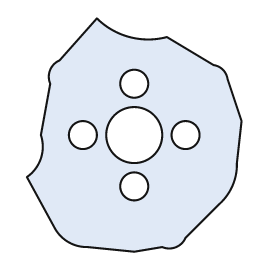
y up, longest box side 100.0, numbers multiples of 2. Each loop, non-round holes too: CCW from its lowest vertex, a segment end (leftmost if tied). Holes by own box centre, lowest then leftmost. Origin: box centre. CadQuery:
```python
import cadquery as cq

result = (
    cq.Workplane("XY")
    .moveTo(0.0, -50.0)
    .lineTo(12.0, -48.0)
    .threePointArc((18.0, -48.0), (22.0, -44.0))
    .lineTo(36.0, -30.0)
    .threePointArc((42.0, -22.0), (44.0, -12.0))
    .lineTo(46.0, 6.0)
    .lineTo(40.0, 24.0)
    .threePointArc((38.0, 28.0), (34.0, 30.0))
    .lineTo(14.0, 42.0)
    .threePointArc((-2.0, 42.0), (-16.0, 50.0))
    .lineTo(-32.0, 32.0)
    .threePointArc((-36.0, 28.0), (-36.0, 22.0))
    .lineTo(-40.0, 0.0)
    .threePointArc((-40.0, -10.0), (-46.0, -18.0))
    .lineTo(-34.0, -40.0)
    .threePointArc((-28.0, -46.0), (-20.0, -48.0))
    .close()
    .moveTo(0.0, -22.0)
    .circle(6.0)
    .moveTo(-22.0, 0.0)
    .circle(6.0)
    .moveTo(0.0, 0.0)
    .circle(12.0)
    .moveTo(22.0, 0.0)
    .circle(6.0)
    .moveTo(0.0, 22.0)
    .circle(6.0)
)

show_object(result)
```